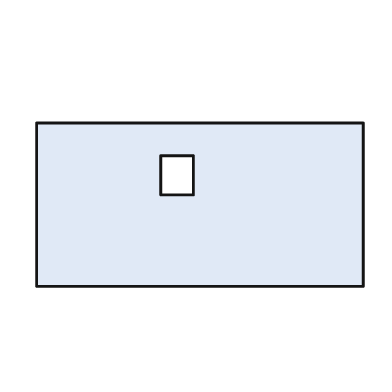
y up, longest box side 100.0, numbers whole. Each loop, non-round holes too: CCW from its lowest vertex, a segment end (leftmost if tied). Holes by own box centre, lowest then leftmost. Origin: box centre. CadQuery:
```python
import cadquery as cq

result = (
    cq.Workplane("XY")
    .moveTo(-50.0, -25.0)
    .lineTo(50.0, -25.0)
    .lineTo(50.0, 25.0)
    .lineTo(-50.0, 25.0)
    .close()
    .moveTo(-12.0, 3.0)
    .lineTo(-2.0, 3.0)
    .lineTo(-2.0, 15.0)
    .lineTo(-12.0, 15.0)
    .close()
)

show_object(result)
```